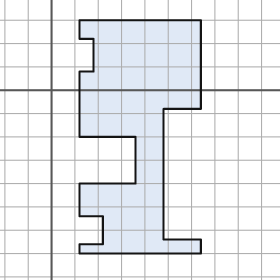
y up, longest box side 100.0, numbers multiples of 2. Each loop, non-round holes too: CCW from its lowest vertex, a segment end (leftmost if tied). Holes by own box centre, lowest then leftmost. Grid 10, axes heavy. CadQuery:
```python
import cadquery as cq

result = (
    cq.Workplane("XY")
    .moveTo(12.0, -70.0)
    .lineTo(64.0, -70.0)
    .lineTo(64.0, -64.0)
    .lineTo(48.0, -64.0)
    .lineTo(48.0, -8.0)
    .lineTo(64.0, -8.0)
    .lineTo(64.0, 30.0)
    .lineTo(12.0, 30.0)
    .lineTo(12.0, 22.0)
    .lineTo(18.0, 22.0)
    .lineTo(18.0, 8.0)
    .lineTo(12.0, 8.0)
    .lineTo(12.0, -20.0)
    .lineTo(36.0, -20.0)
    .lineTo(36.0, -40.0)
    .lineTo(12.0, -40.0)
    .lineTo(12.0, -54.0)
    .lineTo(22.0, -54.0)
    .lineTo(22.0, -66.0)
    .lineTo(12.0, -66.0)
    .close()
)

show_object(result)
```